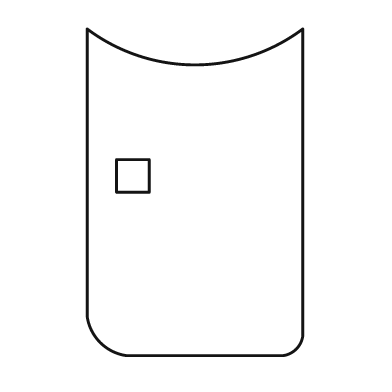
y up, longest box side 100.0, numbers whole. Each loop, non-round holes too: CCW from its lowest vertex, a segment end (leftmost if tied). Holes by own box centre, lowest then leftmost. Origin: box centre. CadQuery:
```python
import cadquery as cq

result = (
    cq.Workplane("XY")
    .moveTo(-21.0, -50.0)
    .lineTo(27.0, -50.0)
    .threePointArc((31.0, -48.0), (33.0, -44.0))
    .lineTo(33.0, 50.0)
    .threePointArc((0.0, 39.0), (-33.0, 50.0))
    .lineTo(-33.0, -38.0)
    .threePointArc((-29.0, -46.0), (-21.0, -50.0))
    .close()
    .moveTo(-24.0, 0.0)
    .lineTo(-14.0, 0.0)
    .lineTo(-14.0, 10.0)
    .lineTo(-24.0, 10.0)
    .close()
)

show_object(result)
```